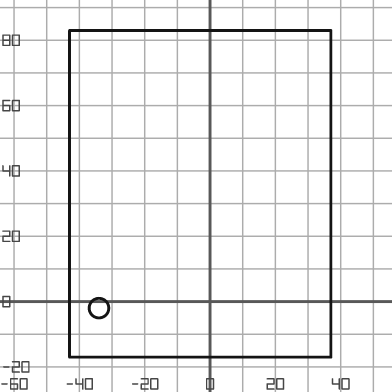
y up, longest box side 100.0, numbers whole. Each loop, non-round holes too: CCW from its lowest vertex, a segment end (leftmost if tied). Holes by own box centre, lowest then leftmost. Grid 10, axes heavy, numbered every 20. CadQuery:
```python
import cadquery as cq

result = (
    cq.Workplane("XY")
    .moveTo(-43.0, -17.0)
    .lineTo(37.0, -17.0)
    .lineTo(37.0, 83.0)
    .lineTo(-43.0, 83.0)
    .close()
    .moveTo(-34.0, -2.0)
    .circle(3.0)
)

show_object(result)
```